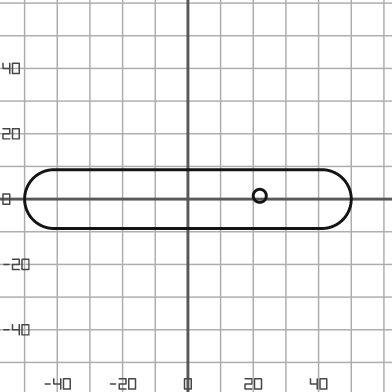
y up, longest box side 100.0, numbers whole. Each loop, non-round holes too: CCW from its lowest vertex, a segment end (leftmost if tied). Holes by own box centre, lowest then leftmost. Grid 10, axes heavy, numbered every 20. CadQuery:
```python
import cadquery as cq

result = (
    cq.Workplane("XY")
    .moveTo(-41.0, -9.0)
    .lineTo(41.0, -9.0)
    .threePointArc((50.0, 0.0), (41.0, 9.0))
    .lineTo(-41.0, 9.0)
    .threePointArc((-50.0, 0.0), (-41.0, -9.0))
    .close()
    .moveTo(22.0, 1.0)
    .circle(2.0)
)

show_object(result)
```